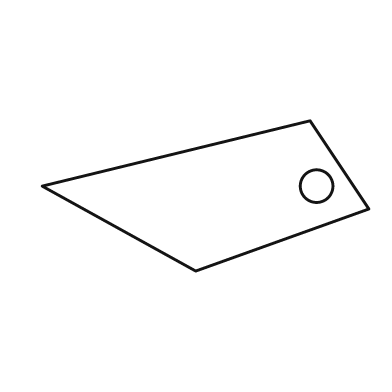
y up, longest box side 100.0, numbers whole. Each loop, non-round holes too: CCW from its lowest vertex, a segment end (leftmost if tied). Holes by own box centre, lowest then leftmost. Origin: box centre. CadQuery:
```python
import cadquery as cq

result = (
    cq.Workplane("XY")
    .moveTo(-3.0, -23.0)
    .lineTo(50.0, -4.0)
    .lineTo(32.0, 23.0)
    .lineTo(-50.0, 3.0)
    .close()
    .moveTo(34.0, 3.0)
    .circle(5.0)
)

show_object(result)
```